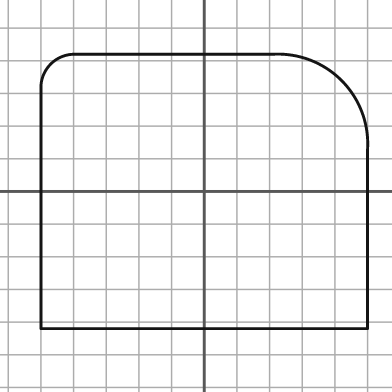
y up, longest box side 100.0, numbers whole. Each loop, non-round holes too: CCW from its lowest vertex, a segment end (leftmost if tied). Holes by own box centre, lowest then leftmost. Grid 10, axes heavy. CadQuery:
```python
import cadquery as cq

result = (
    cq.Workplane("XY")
    .moveTo(-50.0, -42.0)
    .lineTo(50.0, -42.0)
    .lineTo(50.0, 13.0)
    .threePointArc((42.0, 34.0), (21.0, 42.0))
    .lineTo(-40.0, 42.0)
    .threePointArc((-47.0, 39.0), (-50.0, 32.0))
    .close()
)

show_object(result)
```